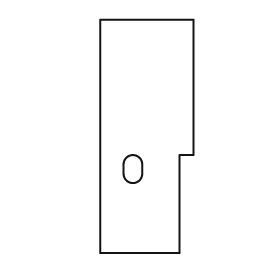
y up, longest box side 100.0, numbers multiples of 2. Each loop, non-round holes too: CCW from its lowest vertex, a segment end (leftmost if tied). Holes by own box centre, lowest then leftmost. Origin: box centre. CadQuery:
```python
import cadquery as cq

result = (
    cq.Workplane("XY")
    .moveTo(-20.0, -50.0)
    .lineTo(14.0, -50.0)
    .lineTo(14.0, -8.0)
    .lineTo(20.0, -8.0)
    .lineTo(20.0, 50.0)
    .lineTo(-20.0, 50.0)
    .close()
    .moveTo(-10.0, -16.0)
    .threePointArc((-6.0, -20.0), (-2.0, -16.0))
    .lineTo(-2.0, -12.0)
    .threePointArc((-6.0, -8.0), (-10.0, -12.0))
    .close()
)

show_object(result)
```